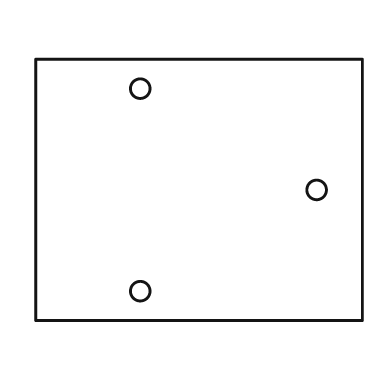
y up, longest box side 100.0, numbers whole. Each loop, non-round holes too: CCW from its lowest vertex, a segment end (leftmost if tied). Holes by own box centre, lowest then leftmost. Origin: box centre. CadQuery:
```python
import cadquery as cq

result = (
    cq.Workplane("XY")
    .moveTo(-50.0, -40.0)
    .lineTo(50.0, -40.0)
    .lineTo(50.0, 40.0)
    .lineTo(-50.0, 40.0)
    .close()
    .moveTo(-18.0, -31.0)
    .circle(3.0)
    .moveTo(36.0, 0.0)
    .circle(3.0)
    .moveTo(-18.0, 31.0)
    .circle(3.0)
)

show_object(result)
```